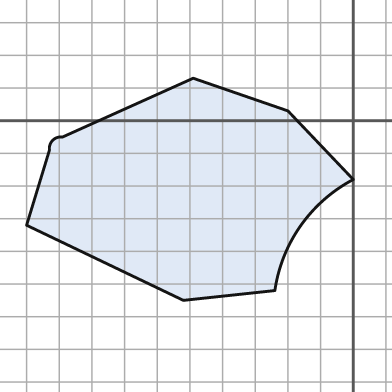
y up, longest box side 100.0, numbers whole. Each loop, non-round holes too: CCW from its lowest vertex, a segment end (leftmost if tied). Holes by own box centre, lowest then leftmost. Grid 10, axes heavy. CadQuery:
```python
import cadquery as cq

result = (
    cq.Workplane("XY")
    .moveTo(-52.0, -55.0)
    .lineTo(-24.0, -52.0)
    .threePointArc((-16.0, -32.0), (0.0, -18.0))
    .lineTo(-20.0, 3.0)
    .lineTo(-49.0, 13.0)
    .lineTo(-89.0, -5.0)
    .threePointArc((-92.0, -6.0), (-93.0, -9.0))
    .lineTo(-100.0, -32.0)
    .close()
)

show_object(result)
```